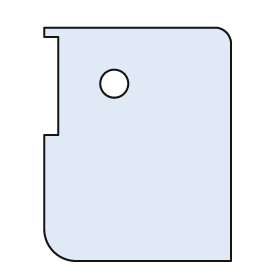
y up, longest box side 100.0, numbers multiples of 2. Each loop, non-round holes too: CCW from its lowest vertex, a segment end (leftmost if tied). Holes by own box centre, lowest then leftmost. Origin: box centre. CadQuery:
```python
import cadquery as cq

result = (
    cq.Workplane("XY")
    .moveTo(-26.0, -50.0)
    .lineTo(40.0, -50.0)
    .lineTo(40.0, 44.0)
    .threePointArc((38.0, 48.0), (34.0, 50.0))
    .lineTo(-40.0, 50.0)
    .lineTo(-40.0, 46.0)
    .lineTo(-34.0, 46.0)
    .lineTo(-34.0, 4.0)
    .lineTo(-40.0, 4.0)
    .lineTo(-40.0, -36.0)
    .threePointArc((-36.0, -46.0), (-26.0, -50.0))
    .close()
    .moveTo(-10.0, 26.0)
    .circle(6.0)
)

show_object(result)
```